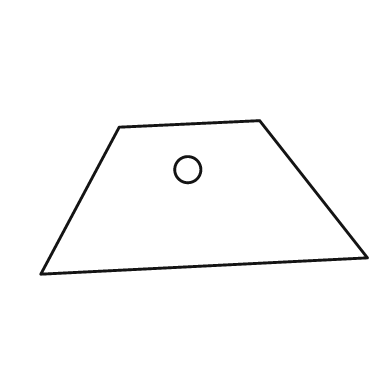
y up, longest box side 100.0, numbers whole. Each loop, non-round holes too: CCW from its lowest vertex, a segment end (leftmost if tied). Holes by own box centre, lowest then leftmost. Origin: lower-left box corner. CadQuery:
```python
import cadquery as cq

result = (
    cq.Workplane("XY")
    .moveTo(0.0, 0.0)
    .lineTo(100.0, 5.0)
    .lineTo(67.0, 47.0)
    .lineTo(24.0, 45.0)
    .close()
    .moveTo(45.0, 32.0)
    .circle(4.0)
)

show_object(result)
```